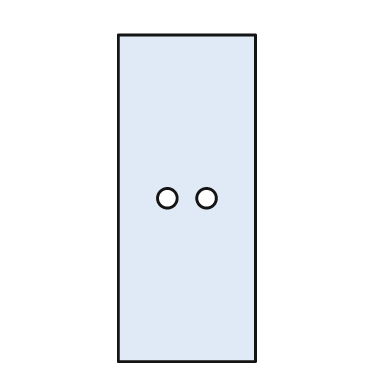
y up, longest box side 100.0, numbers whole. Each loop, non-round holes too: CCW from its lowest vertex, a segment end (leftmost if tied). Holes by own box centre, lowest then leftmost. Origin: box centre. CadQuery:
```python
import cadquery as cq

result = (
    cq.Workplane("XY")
    .moveTo(-21.0, -50.0)
    .lineTo(21.0, -50.0)
    .lineTo(21.0, 50.0)
    .lineTo(-21.0, 50.0)
    .close()
    .moveTo(-6.0, 0.0)
    .circle(3.0)
    .moveTo(6.0, 0.0)
    .circle(3.0)
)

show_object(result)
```